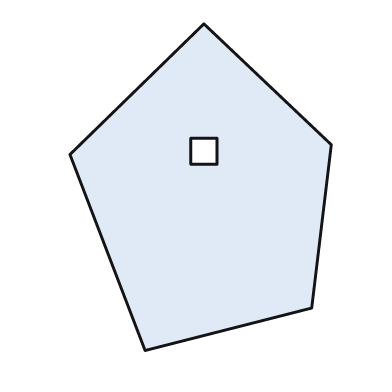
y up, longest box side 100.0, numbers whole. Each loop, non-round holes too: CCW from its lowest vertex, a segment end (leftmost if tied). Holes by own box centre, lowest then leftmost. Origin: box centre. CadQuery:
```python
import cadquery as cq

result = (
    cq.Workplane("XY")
    .moveTo(-17.0, -50.0)
    .lineTo(34.0, -37.0)
    .lineTo(40.0, 13.0)
    .lineTo(1.0, 50.0)
    .lineTo(-40.0, 10.0)
    .close()
    .moveTo(-3.0, 7.0)
    .lineTo(5.0, 7.0)
    .lineTo(5.0, 15.0)
    .lineTo(-3.0, 15.0)
    .close()
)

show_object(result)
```